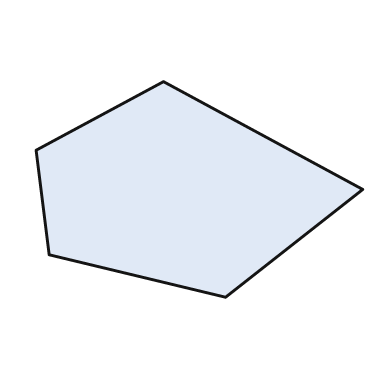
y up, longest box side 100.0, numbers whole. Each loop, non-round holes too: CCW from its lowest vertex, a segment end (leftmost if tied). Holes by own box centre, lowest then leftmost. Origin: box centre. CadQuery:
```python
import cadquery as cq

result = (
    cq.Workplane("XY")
    .moveTo(8.0, -33.0)
    .lineTo(50.0, 0.0)
    .lineTo(-11.0, 33.0)
    .lineTo(-50.0, 12.0)
    .lineTo(-46.0, -20.0)
    .close()
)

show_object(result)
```